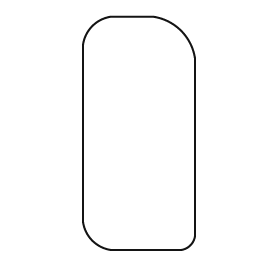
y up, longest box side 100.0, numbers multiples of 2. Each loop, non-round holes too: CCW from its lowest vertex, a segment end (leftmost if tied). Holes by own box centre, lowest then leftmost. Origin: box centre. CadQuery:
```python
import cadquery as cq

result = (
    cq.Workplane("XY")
    .moveTo(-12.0, -50.0)
    .lineTo(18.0, -50.0)
    .threePointArc((22.0, -48.0), (24.0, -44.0))
    .lineTo(24.0, 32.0)
    .threePointArc((18.0, 44.0), (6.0, 50.0))
    .lineTo(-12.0, 50.0)
    .threePointArc((-20.0, 46.0), (-24.0, 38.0))
    .lineTo(-24.0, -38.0)
    .threePointArc((-20.0, -46.0), (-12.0, -50.0))
    .close()
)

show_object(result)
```